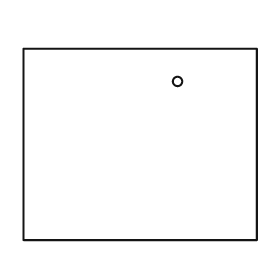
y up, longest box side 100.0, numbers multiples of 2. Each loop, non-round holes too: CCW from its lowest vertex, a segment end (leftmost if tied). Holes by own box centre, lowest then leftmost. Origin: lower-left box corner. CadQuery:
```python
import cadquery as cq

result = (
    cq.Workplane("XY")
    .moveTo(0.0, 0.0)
    .lineTo(100.0, 0.0)
    .lineTo(100.0, 82.0)
    .lineTo(0.0, 82.0)
    .close()
    .moveTo(66.0, 68.0)
    .circle(2.0)
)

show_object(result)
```